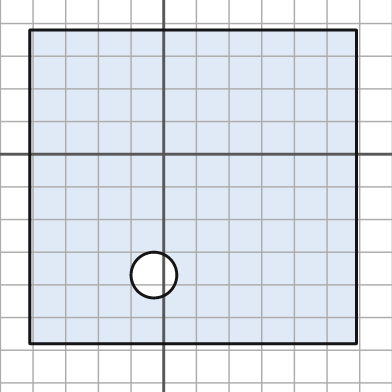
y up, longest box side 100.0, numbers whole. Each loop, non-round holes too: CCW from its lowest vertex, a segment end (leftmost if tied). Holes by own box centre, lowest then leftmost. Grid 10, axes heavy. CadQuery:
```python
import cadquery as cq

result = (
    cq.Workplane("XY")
    .moveTo(-41.0, -58.0)
    .lineTo(59.0, -58.0)
    .lineTo(59.0, 38.0)
    .lineTo(-41.0, 38.0)
    .close()
    .moveTo(-3.0, -37.0)
    .circle(7.0)
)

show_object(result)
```